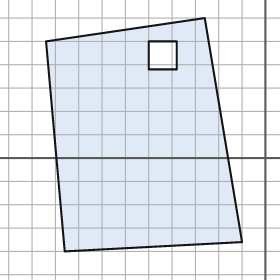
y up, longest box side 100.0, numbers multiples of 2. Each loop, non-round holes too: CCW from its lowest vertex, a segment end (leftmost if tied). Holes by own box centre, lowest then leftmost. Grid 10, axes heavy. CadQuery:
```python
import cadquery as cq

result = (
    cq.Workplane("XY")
    .moveTo(-86.0, -40.0)
    .lineTo(-10.0, -36.0)
    .lineTo(-26.0, 60.0)
    .lineTo(-94.0, 50.0)
    .close()
    .moveTo(-50.0, 38.0)
    .lineTo(-38.0, 38.0)
    .lineTo(-38.0, 50.0)
    .lineTo(-50.0, 50.0)
    .close()
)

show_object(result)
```